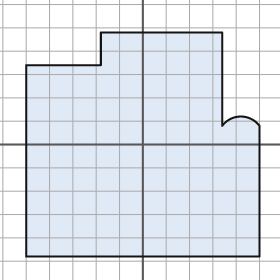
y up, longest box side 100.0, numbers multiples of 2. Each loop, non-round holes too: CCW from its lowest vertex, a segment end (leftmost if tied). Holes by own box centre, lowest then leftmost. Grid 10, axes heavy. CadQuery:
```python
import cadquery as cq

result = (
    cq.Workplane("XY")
    .moveTo(-50.0, -48.0)
    .lineTo(50.0, -48.0)
    .lineTo(50.0, 8.0)
    .threePointArc((42.0, 12.0), (34.0, 8.0))
    .lineTo(34.0, 48.0)
    .lineTo(-18.0, 48.0)
    .lineTo(-18.0, 34.0)
    .lineTo(-50.0, 34.0)
    .close()
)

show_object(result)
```